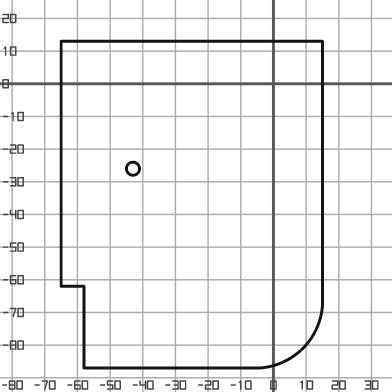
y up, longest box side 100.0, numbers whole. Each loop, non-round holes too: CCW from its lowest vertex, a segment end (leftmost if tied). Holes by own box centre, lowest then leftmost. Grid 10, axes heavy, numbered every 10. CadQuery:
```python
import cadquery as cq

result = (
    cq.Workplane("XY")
    .moveTo(-58.0, -87.0)
    .lineTo(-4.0, -87.0)
    .threePointArc((9.0, -81.0), (15.0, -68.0))
    .lineTo(15.0, 13.0)
    .lineTo(-65.0, 13.0)
    .lineTo(-65.0, -62.0)
    .lineTo(-58.0, -62.0)
    .close()
    .moveTo(-43.0, -26.0)
    .circle(2.0)
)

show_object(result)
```